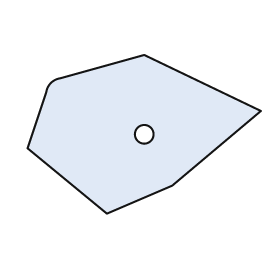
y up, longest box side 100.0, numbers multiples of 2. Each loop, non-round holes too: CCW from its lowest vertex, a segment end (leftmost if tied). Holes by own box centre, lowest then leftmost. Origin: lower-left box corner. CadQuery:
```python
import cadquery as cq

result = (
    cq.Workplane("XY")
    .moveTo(34.0, 0.0)
    .lineTo(62.0, 12.0)
    .lineTo(100.0, 44.0)
    .lineTo(50.0, 68.0)
    .lineTo(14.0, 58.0)
    .threePointArc((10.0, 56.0), (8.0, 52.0))
    .lineTo(0.0, 28.0)
    .close()
    .moveTo(50.0, 34.0)
    .circle(4.0)
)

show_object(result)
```